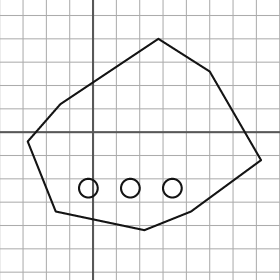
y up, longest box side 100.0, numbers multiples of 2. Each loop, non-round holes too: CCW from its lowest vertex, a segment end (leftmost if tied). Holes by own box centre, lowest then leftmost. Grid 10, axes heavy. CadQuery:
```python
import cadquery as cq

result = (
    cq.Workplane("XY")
    .moveTo(22.0, -42.0)
    .lineTo(42.0, -34.0)
    .lineTo(72.0, -12.0)
    .lineTo(50.0, 26.0)
    .lineTo(28.0, 40.0)
    .lineTo(-14.0, 12.0)
    .lineTo(-28.0, -4.0)
    .lineTo(-16.0, -34.0)
    .close()
    .moveTo(-2.0, -24.0)
    .circle(4.0)
    .moveTo(16.0, -24.0)
    .circle(4.0)
    .moveTo(34.0, -24.0)
    .circle(4.0)
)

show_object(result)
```